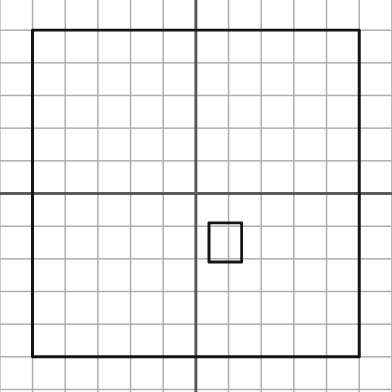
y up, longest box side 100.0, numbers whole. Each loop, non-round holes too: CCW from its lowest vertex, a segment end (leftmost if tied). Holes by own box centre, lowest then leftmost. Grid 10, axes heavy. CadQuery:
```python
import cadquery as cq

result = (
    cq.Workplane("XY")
    .moveTo(-50.0, -50.0)
    .lineTo(50.0, -50.0)
    .lineTo(50.0, 50.0)
    .lineTo(-50.0, 50.0)
    .close()
    .moveTo(4.0, -21.0)
    .lineTo(14.0, -21.0)
    .lineTo(14.0, -9.0)
    .lineTo(4.0, -9.0)
    .close()
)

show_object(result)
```